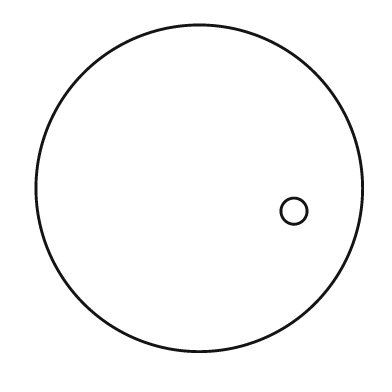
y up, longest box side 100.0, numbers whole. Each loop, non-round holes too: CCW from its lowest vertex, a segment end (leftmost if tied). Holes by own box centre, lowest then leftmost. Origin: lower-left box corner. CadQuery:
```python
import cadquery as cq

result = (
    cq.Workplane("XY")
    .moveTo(50.0, 50.0)
    .circle(50.0)
    .moveTo(79.0, 43.0)
    .circle(4.0)
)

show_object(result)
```